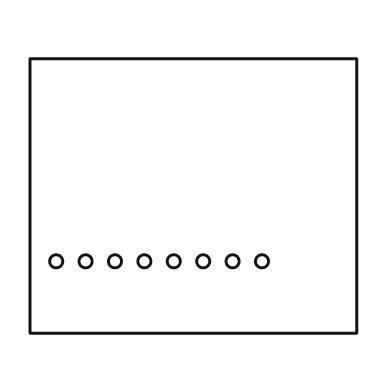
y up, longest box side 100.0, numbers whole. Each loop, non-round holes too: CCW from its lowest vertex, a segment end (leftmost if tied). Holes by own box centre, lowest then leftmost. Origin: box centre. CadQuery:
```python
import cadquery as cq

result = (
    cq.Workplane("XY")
    .moveTo(-50.0, -42.0)
    .lineTo(50.0, -42.0)
    .lineTo(50.0, 42.0)
    .lineTo(-50.0, 42.0)
    .close()
    .moveTo(-42.0, -20.0)
    .circle(2.0)
    .moveTo(-33.0, -20.0)
    .circle(2.0)
    .moveTo(-24.0, -20.0)
    .circle(2.0)
    .moveTo(-15.0, -20.0)
    .circle(2.0)
    .moveTo(-6.0, -20.0)
    .circle(2.0)
    .moveTo(3.0, -20.0)
    .circle(2.0)
    .moveTo(12.0, -20.0)
    .circle(2.0)
    .moveTo(21.0, -20.0)
    .circle(2.0)
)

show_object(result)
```